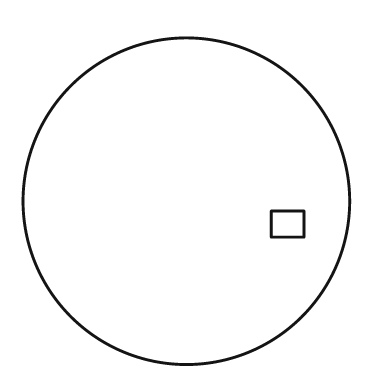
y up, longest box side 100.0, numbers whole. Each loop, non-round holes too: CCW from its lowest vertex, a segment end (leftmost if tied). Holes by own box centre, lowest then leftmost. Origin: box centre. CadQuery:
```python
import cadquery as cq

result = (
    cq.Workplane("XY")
    .moveTo(0.0, 0.0)
    .circle(50.0)
    .moveTo(26.0, -11.0)
    .lineTo(36.0, -11.0)
    .lineTo(36.0, -3.0)
    .lineTo(26.0, -3.0)
    .close()
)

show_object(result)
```